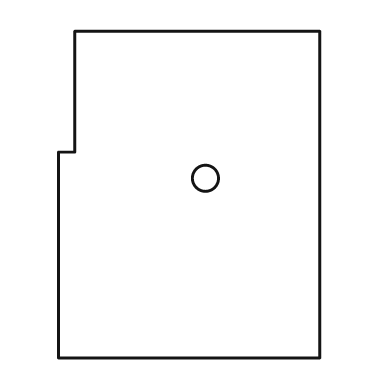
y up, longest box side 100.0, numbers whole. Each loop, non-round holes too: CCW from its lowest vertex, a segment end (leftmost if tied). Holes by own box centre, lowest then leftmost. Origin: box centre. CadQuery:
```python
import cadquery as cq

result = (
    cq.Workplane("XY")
    .moveTo(-40.0, -50.0)
    .lineTo(40.0, -50.0)
    .lineTo(40.0, 50.0)
    .lineTo(-35.0, 50.0)
    .lineTo(-35.0, 13.0)
    .lineTo(-40.0, 13.0)
    .close()
    .moveTo(5.0, 5.0)
    .circle(4.0)
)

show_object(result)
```